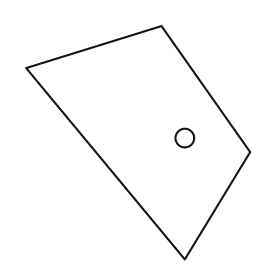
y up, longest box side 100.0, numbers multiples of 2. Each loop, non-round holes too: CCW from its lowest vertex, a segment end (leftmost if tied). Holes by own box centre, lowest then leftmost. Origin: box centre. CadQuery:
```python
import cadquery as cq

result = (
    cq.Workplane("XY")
    .moveTo(20.0, -50.0)
    .lineTo(48.0, -4.0)
    .lineTo(10.0, 50.0)
    .lineTo(-48.0, 32.0)
    .close()
    .moveTo(20.0, 2.0)
    .circle(4.0)
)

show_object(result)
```